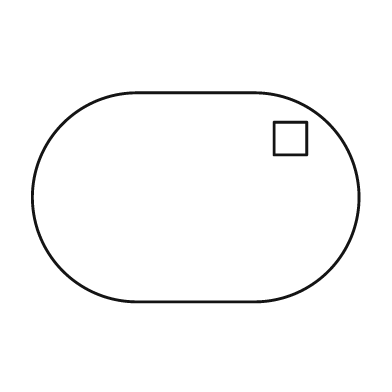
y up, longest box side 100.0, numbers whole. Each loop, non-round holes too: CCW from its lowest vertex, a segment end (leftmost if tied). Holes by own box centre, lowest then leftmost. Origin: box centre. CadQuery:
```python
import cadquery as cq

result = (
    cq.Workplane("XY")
    .moveTo(-18.0, -32.0)
    .lineTo(18.0, -32.0)
    .threePointArc((50.0, 0.0), (18.0, 32.0))
    .lineTo(-18.0, 32.0)
    .threePointArc((-50.0, 0.0), (-18.0, -32.0))
    .close()
    .moveTo(24.0, 13.0)
    .lineTo(34.0, 13.0)
    .lineTo(34.0, 23.0)
    .lineTo(24.0, 23.0)
    .close()
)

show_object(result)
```